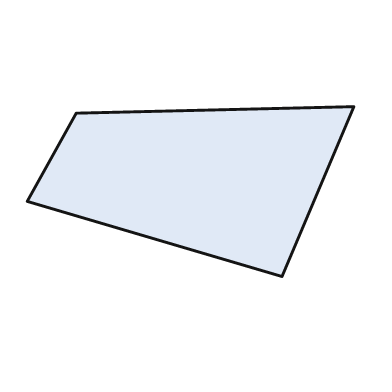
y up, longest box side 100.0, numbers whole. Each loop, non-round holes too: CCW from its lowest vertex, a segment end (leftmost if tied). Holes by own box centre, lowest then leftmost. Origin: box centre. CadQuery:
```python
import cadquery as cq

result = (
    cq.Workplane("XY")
    .moveTo(28.0, -26.0)
    .lineTo(50.0, 26.0)
    .lineTo(-35.0, 24.0)
    .lineTo(-50.0, -3.0)
    .close()
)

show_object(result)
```